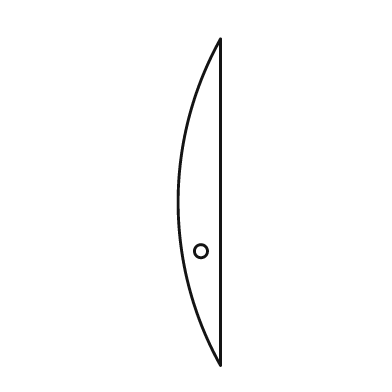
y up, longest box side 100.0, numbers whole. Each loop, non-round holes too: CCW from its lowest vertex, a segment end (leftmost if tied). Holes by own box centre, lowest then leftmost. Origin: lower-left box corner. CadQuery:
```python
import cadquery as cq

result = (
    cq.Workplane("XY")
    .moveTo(13.0, 0.0)
    .lineTo(13.0, 100.0)
    .threePointArc((0.0, 50.0), (13.0, 0.0))
    .close()
    .moveTo(7.0, 35.0)
    .circle(2.0)
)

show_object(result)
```